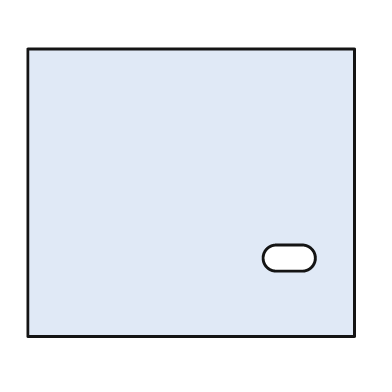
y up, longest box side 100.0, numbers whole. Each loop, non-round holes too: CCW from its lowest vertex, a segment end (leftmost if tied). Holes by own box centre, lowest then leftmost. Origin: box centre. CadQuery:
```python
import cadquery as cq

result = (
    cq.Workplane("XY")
    .moveTo(-50.0, -44.0)
    .lineTo(50.0, -44.0)
    .lineTo(50.0, 44.0)
    .lineTo(-50.0, 44.0)
    .close()
    .moveTo(26.0, -24.0)
    .lineTo(34.0, -24.0)
    .threePointArc((38.0, -20.0), (34.0, -16.0))
    .lineTo(26.0, -16.0)
    .threePointArc((22.0, -20.0), (26.0, -24.0))
    .close()
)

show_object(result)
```